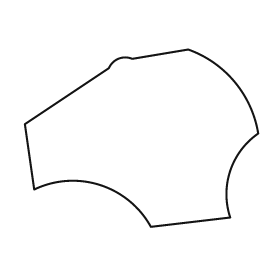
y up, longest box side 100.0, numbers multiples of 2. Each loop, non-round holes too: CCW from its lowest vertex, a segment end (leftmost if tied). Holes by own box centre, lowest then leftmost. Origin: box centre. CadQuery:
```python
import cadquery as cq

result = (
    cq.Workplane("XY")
    .moveTo(4.0, -38.0)
    .lineTo(38.0, -34.0)
    .threePointArc((38.0, -14.0), (50.0, 2.0))
    .threePointArc((40.0, 24.0), (20.0, 38.0))
    .lineTo(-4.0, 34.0)
    .threePointArc((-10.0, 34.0), (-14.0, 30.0))
    .lineTo(-50.0, 6.0)
    .lineTo(-46.0, -22.0)
    .threePointArc((-18.0, -20.0), (4.0, -38.0))
    .close()
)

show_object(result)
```